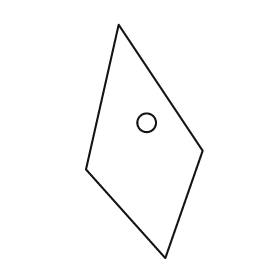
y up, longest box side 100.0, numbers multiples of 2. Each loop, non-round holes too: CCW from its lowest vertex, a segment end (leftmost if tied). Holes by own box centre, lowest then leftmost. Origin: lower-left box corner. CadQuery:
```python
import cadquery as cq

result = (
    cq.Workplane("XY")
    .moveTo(34.0, 0.0)
    .lineTo(50.0, 46.0)
    .lineTo(14.0, 100.0)
    .lineTo(0.0, 38.0)
    .close()
    .moveTo(26.0, 58.0)
    .circle(4.0)
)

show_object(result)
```